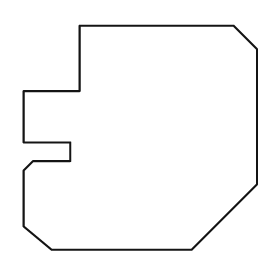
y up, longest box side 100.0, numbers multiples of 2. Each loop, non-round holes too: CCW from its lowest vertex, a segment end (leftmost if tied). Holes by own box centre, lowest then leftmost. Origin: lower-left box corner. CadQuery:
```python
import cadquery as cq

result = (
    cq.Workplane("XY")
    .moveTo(12.0, 0.0)
    .lineTo(72.0, 0.0)
    .lineTo(100.0, 28.0)
    .lineTo(100.0, 86.0)
    .lineTo(90.0, 96.0)
    .lineTo(24.0, 96.0)
    .lineTo(24.0, 68.0)
    .lineTo(0.0, 68.0)
    .lineTo(0.0, 46.0)
    .lineTo(20.0, 46.0)
    .lineTo(20.0, 38.0)
    .lineTo(4.0, 38.0)
    .lineTo(0.0, 34.0)
    .lineTo(0.0, 10.0)
    .close()
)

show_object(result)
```